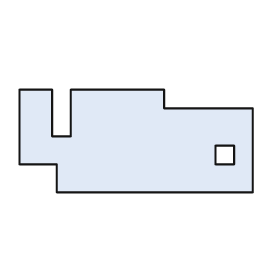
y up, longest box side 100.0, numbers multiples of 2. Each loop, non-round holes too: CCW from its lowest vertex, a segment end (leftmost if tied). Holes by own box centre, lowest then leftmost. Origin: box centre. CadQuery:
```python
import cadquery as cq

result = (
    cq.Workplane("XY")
    .moveTo(-34.0, -22.0)
    .lineTo(50.0, -22.0)
    .lineTo(50.0, 14.0)
    .lineTo(12.0, 14.0)
    .lineTo(12.0, 22.0)
    .lineTo(-28.0, 22.0)
    .lineTo(-28.0, 2.0)
    .lineTo(-36.0, 2.0)
    .lineTo(-36.0, 22.0)
    .lineTo(-50.0, 22.0)
    .lineTo(-50.0, -10.0)
    .lineTo(-34.0, -10.0)
    .close()
    .moveTo(34.0, -10.0)
    .lineTo(42.0, -10.0)
    .lineTo(42.0, -2.0)
    .lineTo(34.0, -2.0)
    .close()
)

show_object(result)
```